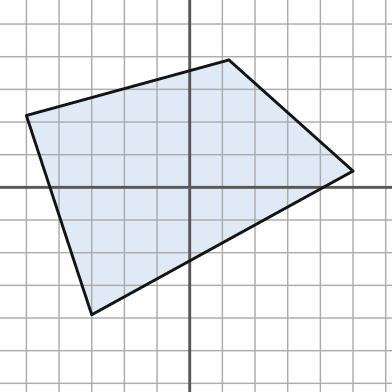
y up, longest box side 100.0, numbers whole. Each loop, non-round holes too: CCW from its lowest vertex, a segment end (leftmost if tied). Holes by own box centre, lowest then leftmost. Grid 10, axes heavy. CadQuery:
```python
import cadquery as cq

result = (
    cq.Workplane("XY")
    .moveTo(-30.0, -39.0)
    .lineTo(50.0, 5.0)
    .lineTo(12.0, 39.0)
    .lineTo(-50.0, 22.0)
    .close()
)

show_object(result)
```